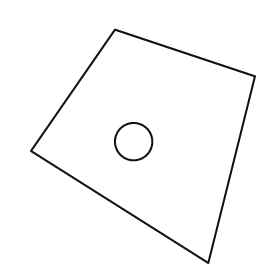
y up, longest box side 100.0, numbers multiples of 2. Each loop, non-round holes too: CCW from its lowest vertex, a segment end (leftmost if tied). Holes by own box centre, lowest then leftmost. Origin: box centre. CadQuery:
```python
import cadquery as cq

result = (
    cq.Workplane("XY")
    .moveTo(28.0, -50.0)
    .lineTo(48.0, 30.0)
    .lineTo(-12.0, 50.0)
    .lineTo(-48.0, -2.0)
    .close()
    .moveTo(-4.0, 2.0)
    .circle(8.0)
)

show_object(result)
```